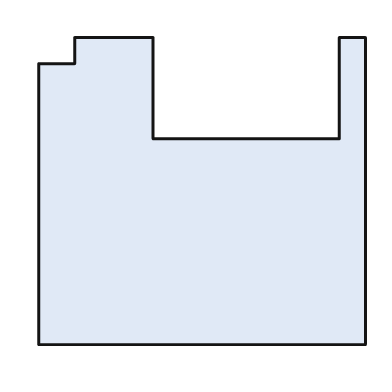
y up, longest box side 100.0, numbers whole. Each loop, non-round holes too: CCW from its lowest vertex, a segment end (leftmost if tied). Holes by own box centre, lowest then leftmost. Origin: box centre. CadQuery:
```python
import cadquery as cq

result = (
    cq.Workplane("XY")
    .moveTo(-50.0, -47.0)
    .lineTo(50.0, -47.0)
    .lineTo(50.0, 47.0)
    .lineTo(42.0, 47.0)
    .lineTo(42.0, 16.0)
    .lineTo(-15.0, 16.0)
    .lineTo(-15.0, 47.0)
    .lineTo(-39.0, 47.0)
    .lineTo(-39.0, 39.0)
    .lineTo(-50.0, 39.0)
    .close()
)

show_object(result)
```